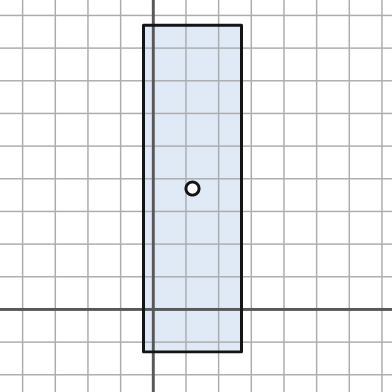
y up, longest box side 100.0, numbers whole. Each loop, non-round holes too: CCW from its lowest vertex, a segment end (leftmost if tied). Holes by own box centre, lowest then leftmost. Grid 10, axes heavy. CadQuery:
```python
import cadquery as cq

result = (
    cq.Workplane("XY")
    .moveTo(-3.0, -13.0)
    .lineTo(27.0, -13.0)
    .lineTo(27.0, 87.0)
    .lineTo(-3.0, 87.0)
    .close()
    .moveTo(12.0, 37.0)
    .circle(2.0)
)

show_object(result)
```